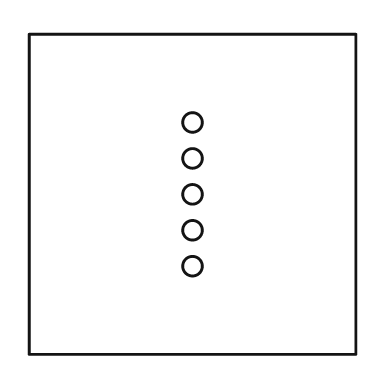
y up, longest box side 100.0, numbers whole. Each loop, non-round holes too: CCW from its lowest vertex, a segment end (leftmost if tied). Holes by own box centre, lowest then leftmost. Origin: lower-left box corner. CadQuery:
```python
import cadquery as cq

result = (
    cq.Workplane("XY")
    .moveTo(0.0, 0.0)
    .lineTo(100.0, 0.0)
    .lineTo(100.0, 98.0)
    .lineTo(0.0, 98.0)
    .close()
    .moveTo(50.0, 27.0)
    .circle(3.0)
    .moveTo(50.0, 38.0)
    .circle(3.0)
    .moveTo(50.0, 49.0)
    .circle(3.0)
    .moveTo(50.0, 60.0)
    .circle(3.0)
    .moveTo(50.0, 71.0)
    .circle(3.0)
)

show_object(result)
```